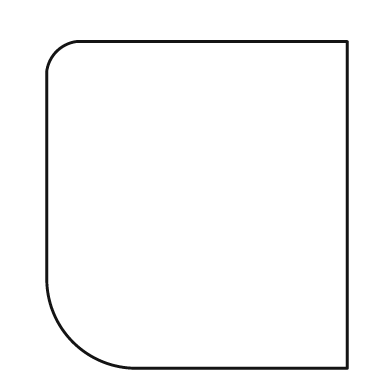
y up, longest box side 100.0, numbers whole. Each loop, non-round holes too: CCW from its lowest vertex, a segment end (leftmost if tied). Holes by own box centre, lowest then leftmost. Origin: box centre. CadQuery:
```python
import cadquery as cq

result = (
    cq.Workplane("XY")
    .moveTo(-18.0, -50.0)
    .lineTo(46.0, -50.0)
    .lineTo(46.0, 50.0)
    .lineTo(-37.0, 50.0)
    .threePointArc((-43.0, 47.0), (-46.0, 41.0))
    .lineTo(-46.0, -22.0)
    .threePointArc((-38.0, -42.0), (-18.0, -50.0))
    .close()
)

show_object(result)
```